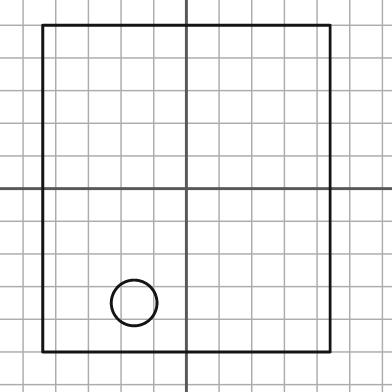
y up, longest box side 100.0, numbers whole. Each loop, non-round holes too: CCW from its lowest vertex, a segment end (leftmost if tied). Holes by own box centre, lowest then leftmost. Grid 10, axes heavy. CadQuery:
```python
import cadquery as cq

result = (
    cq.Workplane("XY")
    .moveTo(-44.0, -50.0)
    .lineTo(44.0, -50.0)
    .lineTo(44.0, 50.0)
    .lineTo(-44.0, 50.0)
    .close()
    .moveTo(-16.0, -35.0)
    .circle(7.0)
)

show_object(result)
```